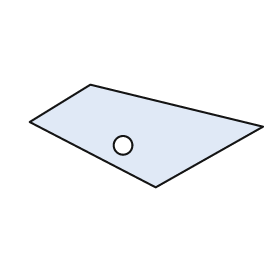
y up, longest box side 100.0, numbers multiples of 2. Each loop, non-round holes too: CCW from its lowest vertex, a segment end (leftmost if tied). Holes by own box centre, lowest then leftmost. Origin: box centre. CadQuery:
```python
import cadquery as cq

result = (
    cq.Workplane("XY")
    .moveTo(4.0, -22.0)
    .lineTo(50.0, 4.0)
    .lineTo(-24.0, 22.0)
    .lineTo(-50.0, 6.0)
    .close()
    .moveTo(-10.0, -4.0)
    .circle(4.0)
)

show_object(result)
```